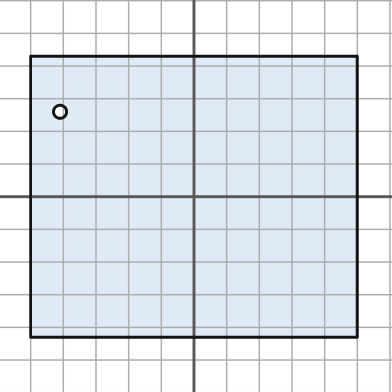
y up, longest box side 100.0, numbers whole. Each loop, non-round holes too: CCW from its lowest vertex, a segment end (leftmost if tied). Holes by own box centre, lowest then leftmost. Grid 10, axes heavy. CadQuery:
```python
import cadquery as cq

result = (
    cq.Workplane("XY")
    .moveTo(-50.0, -43.0)
    .lineTo(50.0, -43.0)
    .lineTo(50.0, 43.0)
    .lineTo(-50.0, 43.0)
    .close()
    .moveTo(-41.0, 26.0)
    .circle(2.0)
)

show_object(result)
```